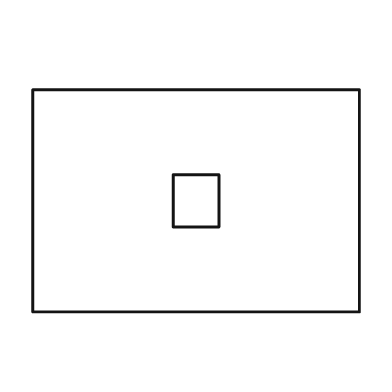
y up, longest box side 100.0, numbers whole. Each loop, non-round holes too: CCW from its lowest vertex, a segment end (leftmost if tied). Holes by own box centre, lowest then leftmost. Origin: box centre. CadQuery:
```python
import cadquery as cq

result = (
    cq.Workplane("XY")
    .moveTo(-50.0, -34.0)
    .lineTo(50.0, -34.0)
    .lineTo(50.0, 34.0)
    .lineTo(-50.0, 34.0)
    .close()
    .moveTo(-7.0, -8.0)
    .lineTo(7.0, -8.0)
    .lineTo(7.0, 8.0)
    .lineTo(-7.0, 8.0)
    .close()
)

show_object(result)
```